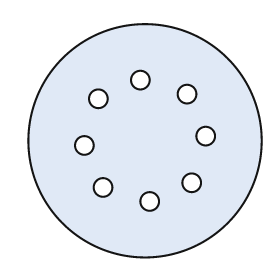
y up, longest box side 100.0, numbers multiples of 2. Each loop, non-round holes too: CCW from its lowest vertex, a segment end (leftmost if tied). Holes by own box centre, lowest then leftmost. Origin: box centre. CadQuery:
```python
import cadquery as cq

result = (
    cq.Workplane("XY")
    .moveTo(0.0, 0.0)
    .circle(50.0)
    .moveTo(2.0, -26.0)
    .circle(4.0)
    .moveTo(-18.0, -20.0)
    .circle(4.0)
    .moveTo(20.0, -18.0)
    .circle(4.0)
    .moveTo(-26.0, -2.0)
    .circle(4.0)
    .moveTo(26.0, 2.0)
    .circle(4.0)
    .moveTo(-20.0, 18.0)
    .circle(4.0)
    .moveTo(18.0, 20.0)
    .circle(4.0)
    .moveTo(-2.0, 26.0)
    .circle(4.0)
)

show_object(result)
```